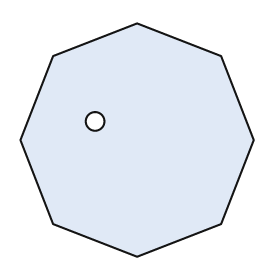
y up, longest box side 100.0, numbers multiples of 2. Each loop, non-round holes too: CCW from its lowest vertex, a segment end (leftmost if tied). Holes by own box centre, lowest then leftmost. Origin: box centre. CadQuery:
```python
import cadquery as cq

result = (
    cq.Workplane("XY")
    .moveTo(0.0, -50.0)
    .lineTo(36.0, -36.0)
    .lineTo(50.0, 0.0)
    .lineTo(36.0, 36.0)
    .lineTo(0.0, 50.0)
    .lineTo(-36.0, 36.0)
    .lineTo(-50.0, 0.0)
    .lineTo(-36.0, -36.0)
    .close()
    .moveTo(-18.0, 8.0)
    .circle(4.0)
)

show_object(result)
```